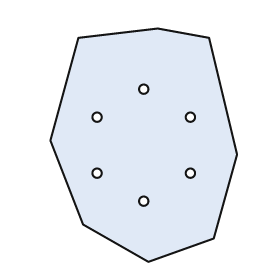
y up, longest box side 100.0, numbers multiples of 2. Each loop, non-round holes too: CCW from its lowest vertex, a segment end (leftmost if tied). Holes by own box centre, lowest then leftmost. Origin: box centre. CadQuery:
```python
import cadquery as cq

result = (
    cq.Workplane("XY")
    .moveTo(2.0, -50.0)
    .lineTo(30.0, -40.0)
    .lineTo(40.0, -4.0)
    .lineTo(28.0, 46.0)
    .lineTo(6.0, 50.0)
    .lineTo(-28.0, 46.0)
    .lineTo(-40.0, 2.0)
    .lineTo(-26.0, -34.0)
    .close()
    .moveTo(0.0, -24.0)
    .circle(2.0)
    .moveTo(-20.0, -12.0)
    .circle(2.0)
    .moveTo(20.0, -12.0)
    .circle(2.0)
    .moveTo(-20.0, 12.0)
    .circle(2.0)
    .moveTo(20.0, 12.0)
    .circle(2.0)
    .moveTo(0.0, 24.0)
    .circle(2.0)
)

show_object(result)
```